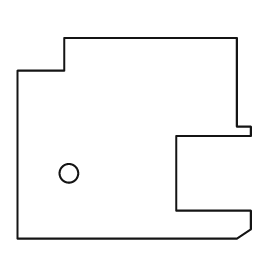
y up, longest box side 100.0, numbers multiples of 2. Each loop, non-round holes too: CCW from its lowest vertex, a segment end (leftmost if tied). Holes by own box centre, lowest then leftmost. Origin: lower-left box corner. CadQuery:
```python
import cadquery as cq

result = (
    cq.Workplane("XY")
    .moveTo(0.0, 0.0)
    .lineTo(94.0, 0.0)
    .lineTo(100.0, 4.0)
    .lineTo(100.0, 12.0)
    .lineTo(68.0, 12.0)
    .lineTo(68.0, 44.0)
    .lineTo(100.0, 44.0)
    .lineTo(100.0, 48.0)
    .lineTo(94.0, 48.0)
    .lineTo(94.0, 86.0)
    .lineTo(20.0, 86.0)
    .lineTo(20.0, 72.0)
    .lineTo(0.0, 72.0)
    .close()
    .moveTo(22.0, 28.0)
    .circle(4.0)
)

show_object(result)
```